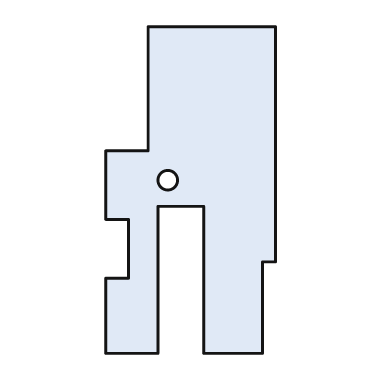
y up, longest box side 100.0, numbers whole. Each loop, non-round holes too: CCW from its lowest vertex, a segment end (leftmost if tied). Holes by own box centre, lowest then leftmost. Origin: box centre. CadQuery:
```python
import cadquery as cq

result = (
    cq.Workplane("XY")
    .moveTo(-26.0, -50.0)
    .lineTo(-10.0, -50.0)
    .lineTo(-10.0, -5.0)
    .lineTo(4.0, -5.0)
    .lineTo(4.0, -50.0)
    .lineTo(22.0, -50.0)
    .lineTo(22.0, -22.0)
    .lineTo(26.0, -22.0)
    .lineTo(26.0, 50.0)
    .lineTo(-13.0, 50.0)
    .lineTo(-13.0, 12.0)
    .lineTo(-26.0, 12.0)
    .lineTo(-26.0, -9.0)
    .lineTo(-19.0, -9.0)
    .lineTo(-19.0, -27.0)
    .lineTo(-26.0, -27.0)
    .close()
    .moveTo(-7.0, 3.0)
    .circle(3.0)
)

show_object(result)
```